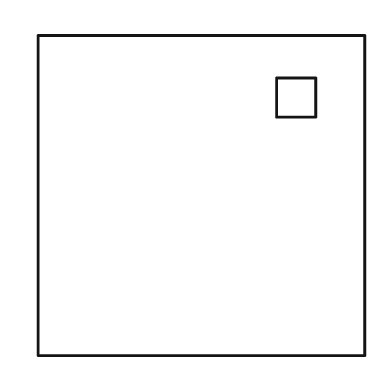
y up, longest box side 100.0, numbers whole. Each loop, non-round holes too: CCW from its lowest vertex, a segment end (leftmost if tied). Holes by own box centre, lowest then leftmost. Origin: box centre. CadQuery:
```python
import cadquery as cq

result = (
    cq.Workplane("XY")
    .moveTo(-50.0, -49.0)
    .lineTo(50.0, -49.0)
    .lineTo(50.0, 49.0)
    .lineTo(-50.0, 49.0)
    .close()
    .moveTo(23.0, 24.0)
    .lineTo(35.0, 24.0)
    .lineTo(35.0, 36.0)
    .lineTo(23.0, 36.0)
    .close()
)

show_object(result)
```